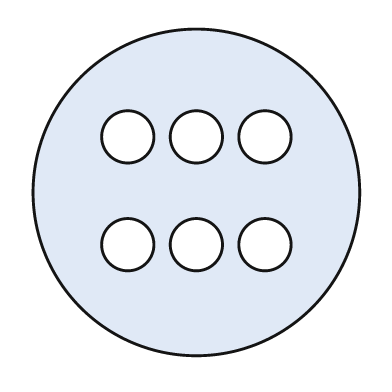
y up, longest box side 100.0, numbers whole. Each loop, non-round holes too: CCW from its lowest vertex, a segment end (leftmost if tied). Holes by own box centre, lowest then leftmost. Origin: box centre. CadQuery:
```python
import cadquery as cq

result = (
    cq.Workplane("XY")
    .moveTo(0.0, 0.0)
    .circle(50.0)
    .moveTo(-21.0, -16.0)
    .circle(8.0)
    .moveTo(0.0, -16.0)
    .circle(8.0)
    .moveTo(21.0, -16.0)
    .circle(8.0)
    .moveTo(-21.0, 17.0)
    .circle(8.0)
    .moveTo(0.0, 17.0)
    .circle(8.0)
    .moveTo(21.0, 17.0)
    .circle(8.0)
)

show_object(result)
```